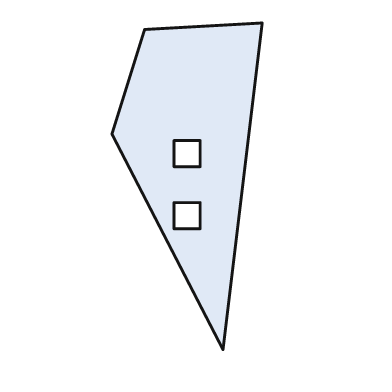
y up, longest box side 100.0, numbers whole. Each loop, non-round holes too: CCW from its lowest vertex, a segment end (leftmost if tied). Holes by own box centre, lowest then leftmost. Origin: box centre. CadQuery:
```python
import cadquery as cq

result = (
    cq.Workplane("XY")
    .moveTo(11.0, -50.0)
    .lineTo(23.0, 50.0)
    .lineTo(-13.0, 48.0)
    .lineTo(-23.0, 16.0)
    .close()
    .moveTo(-4.0, -13.0)
    .lineTo(4.0, -13.0)
    .lineTo(4.0, -5.0)
    .lineTo(-4.0, -5.0)
    .close()
    .moveTo(-4.0, 6.0)
    .lineTo(4.0, 6.0)
    .lineTo(4.0, 14.0)
    .lineTo(-4.0, 14.0)
    .close()
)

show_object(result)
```